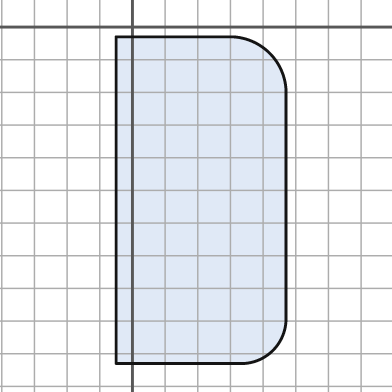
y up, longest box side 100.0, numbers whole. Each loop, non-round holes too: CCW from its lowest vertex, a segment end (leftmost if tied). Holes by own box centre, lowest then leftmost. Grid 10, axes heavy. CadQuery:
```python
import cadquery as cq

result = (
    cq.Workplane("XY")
    .moveTo(-5.0, -103.0)
    .lineTo(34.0, -103.0)
    .threePointArc((43.0, -99.0), (47.0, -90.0))
    .lineTo(47.0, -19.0)
    .threePointArc((42.0, -8.0), (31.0, -3.0))
    .lineTo(-5.0, -3.0)
    .close()
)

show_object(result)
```